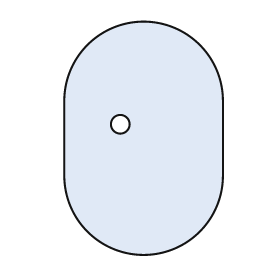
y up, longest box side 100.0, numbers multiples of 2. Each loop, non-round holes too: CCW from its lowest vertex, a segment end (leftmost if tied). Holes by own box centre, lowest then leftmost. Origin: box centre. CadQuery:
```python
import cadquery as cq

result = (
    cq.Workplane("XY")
    .moveTo(-34.0, -16.0)
    .threePointArc((0.0, -50.0), (34.0, -16.0))
    .lineTo(34.0, 16.0)
    .threePointArc((0.0, 50.0), (-34.0, 16.0))
    .close()
    .moveTo(-10.0, 6.0)
    .circle(4.0)
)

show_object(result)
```